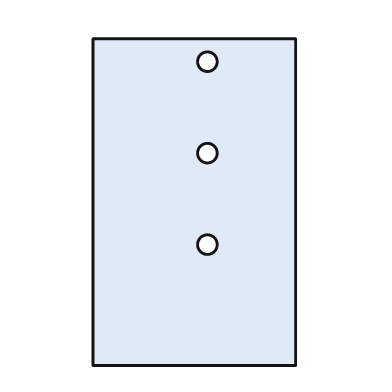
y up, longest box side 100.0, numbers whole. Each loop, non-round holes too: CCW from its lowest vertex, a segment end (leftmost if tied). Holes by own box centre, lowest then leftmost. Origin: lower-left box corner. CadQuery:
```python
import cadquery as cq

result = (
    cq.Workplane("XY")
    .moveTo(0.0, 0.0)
    .lineTo(62.0, 0.0)
    .lineTo(62.0, 100.0)
    .lineTo(0.0, 100.0)
    .close()
    .moveTo(35.0, 37.0)
    .circle(3.0)
    .moveTo(35.0, 65.0)
    .circle(3.0)
    .moveTo(35.0, 93.0)
    .circle(3.0)
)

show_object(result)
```